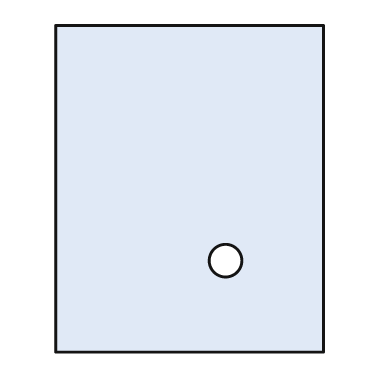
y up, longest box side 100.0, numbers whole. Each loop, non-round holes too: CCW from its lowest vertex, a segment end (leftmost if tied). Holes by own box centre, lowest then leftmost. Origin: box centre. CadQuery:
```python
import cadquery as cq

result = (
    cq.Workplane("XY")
    .moveTo(-41.0, -50.0)
    .lineTo(41.0, -50.0)
    .lineTo(41.0, 50.0)
    .lineTo(-41.0, 50.0)
    .close()
    .moveTo(11.0, -22.0)
    .circle(5.0)
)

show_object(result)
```